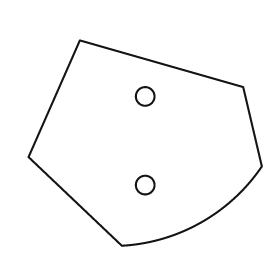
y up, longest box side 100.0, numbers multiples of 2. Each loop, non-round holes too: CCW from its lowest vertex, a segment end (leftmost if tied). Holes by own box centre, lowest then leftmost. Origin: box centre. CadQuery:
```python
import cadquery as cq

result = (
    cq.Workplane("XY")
    .moveTo(-10.0, -44.0)
    .threePointArc((24.0, -34.0), (50.0, -10.0))
    .lineTo(42.0, 24.0)
    .lineTo(-28.0, 44.0)
    .lineTo(-50.0, -6.0)
    .close()
    .moveTo(0.0, -18.0)
    .circle(4.0)
    .moveTo(0.0, 20.0)
    .circle(4.0)
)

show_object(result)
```